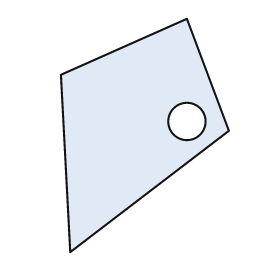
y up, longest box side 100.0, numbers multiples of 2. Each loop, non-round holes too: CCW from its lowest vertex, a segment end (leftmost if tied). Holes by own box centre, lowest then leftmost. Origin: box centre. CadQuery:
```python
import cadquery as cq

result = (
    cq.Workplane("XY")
    .moveTo(-32.0, -50.0)
    .lineTo(36.0, 2.0)
    .lineTo(18.0, 50.0)
    .lineTo(-36.0, 26.0)
    .close()
    .moveTo(18.0, 6.0)
    .circle(8.0)
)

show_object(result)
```